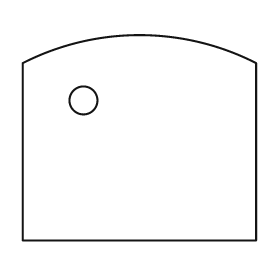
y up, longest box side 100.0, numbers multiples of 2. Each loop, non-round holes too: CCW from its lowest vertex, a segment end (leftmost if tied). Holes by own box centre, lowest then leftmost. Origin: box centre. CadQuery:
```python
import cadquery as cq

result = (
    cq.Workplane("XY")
    .moveTo(-50.0, -44.0)
    .lineTo(50.0, -44.0)
    .lineTo(50.0, 32.0)
    .threePointArc((0.0, 44.0), (-50.0, 32.0))
    .close()
    .moveTo(-24.0, 16.0)
    .circle(6.0)
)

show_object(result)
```